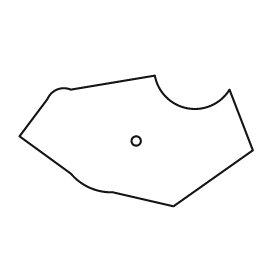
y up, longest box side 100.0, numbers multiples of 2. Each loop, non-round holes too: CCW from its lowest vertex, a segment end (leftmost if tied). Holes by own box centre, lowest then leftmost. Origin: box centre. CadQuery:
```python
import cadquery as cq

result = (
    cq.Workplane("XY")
    .moveTo(16.0, -28.0)
    .lineTo(50.0, -4.0)
    .lineTo(40.0, 22.0)
    .threePointArc((22.0, 14.0), (8.0, 28.0))
    .lineTo(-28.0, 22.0)
    .threePointArc((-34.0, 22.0), (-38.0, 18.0))
    .lineTo(-50.0, 2.0)
    .lineTo(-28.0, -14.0)
    .threePointArc((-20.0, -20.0), (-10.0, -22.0))
    .close()
    .moveTo(0.0, 0.0)
    .circle(2.0)
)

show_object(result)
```